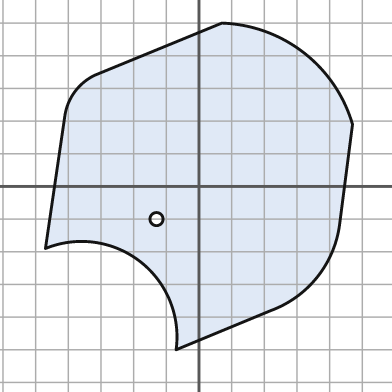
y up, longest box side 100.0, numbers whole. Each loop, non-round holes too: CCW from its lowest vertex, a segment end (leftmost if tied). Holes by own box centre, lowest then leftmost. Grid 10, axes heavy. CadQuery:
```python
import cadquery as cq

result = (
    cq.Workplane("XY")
    .moveTo(-7.0, -50.0)
    .lineTo(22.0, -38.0)
    .threePointArc((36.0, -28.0), (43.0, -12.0))
    .lineTo(47.0, 19.0)
    .threePointArc((32.0, 41.0), (7.0, 50.0))
    .lineTo(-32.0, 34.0)
    .threePointArc((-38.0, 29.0), (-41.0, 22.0))
    .lineTo(-47.0, -19.0)
    .threePointArc((-18.0, -23.0), (-7.0, -50.0))
    .close()
    .moveTo(-13.0, -10.0)
    .circle(2.0)
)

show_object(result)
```